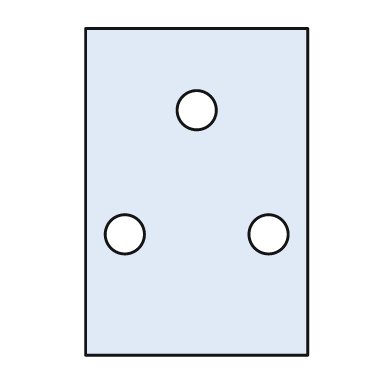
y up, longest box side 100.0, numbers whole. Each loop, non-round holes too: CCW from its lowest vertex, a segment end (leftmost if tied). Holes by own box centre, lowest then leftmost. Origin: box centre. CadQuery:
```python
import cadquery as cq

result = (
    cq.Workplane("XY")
    .moveTo(-34.0, -50.0)
    .lineTo(34.0, -50.0)
    .lineTo(34.0, 50.0)
    .lineTo(-34.0, 50.0)
    .close()
    .moveTo(-22.0, -13.0)
    .circle(6.0)
    .moveTo(22.0, -13.0)
    .circle(6.0)
    .moveTo(0.0, 25.0)
    .circle(6.0)
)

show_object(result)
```